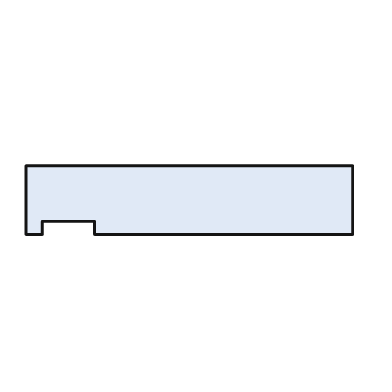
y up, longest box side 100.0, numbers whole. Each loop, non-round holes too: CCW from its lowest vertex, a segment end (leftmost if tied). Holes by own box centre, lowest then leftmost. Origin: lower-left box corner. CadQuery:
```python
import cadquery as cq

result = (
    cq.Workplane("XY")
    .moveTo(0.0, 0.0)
    .lineTo(5.0, 0.0)
    .lineTo(5.0, 4.0)
    .lineTo(21.0, 4.0)
    .lineTo(21.0, 0.0)
    .lineTo(100.0, 0.0)
    .lineTo(100.0, 21.0)
    .lineTo(0.0, 21.0)
    .close()
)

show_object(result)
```